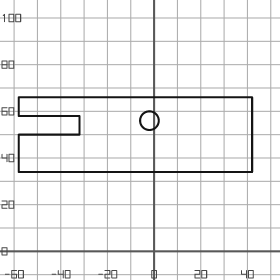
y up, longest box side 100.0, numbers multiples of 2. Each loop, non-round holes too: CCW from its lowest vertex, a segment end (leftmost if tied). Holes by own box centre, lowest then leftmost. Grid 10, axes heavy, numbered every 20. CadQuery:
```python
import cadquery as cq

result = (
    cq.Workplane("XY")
    .moveTo(-58.0, 34.0)
    .lineTo(42.0, 34.0)
    .lineTo(42.0, 66.0)
    .lineTo(-58.0, 66.0)
    .lineTo(-58.0, 58.0)
    .lineTo(-32.0, 58.0)
    .lineTo(-32.0, 50.0)
    .lineTo(-58.0, 50.0)
    .close()
    .moveTo(-2.0, 56.0)
    .circle(4.0)
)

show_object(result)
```